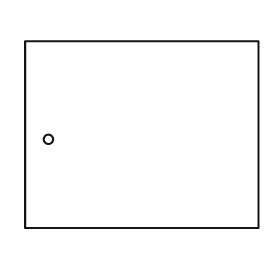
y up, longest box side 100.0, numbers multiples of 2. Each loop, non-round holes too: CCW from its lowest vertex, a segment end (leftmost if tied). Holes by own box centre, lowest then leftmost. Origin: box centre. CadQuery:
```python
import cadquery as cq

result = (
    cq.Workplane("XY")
    .moveTo(-50.0, -40.0)
    .lineTo(50.0, -40.0)
    .lineTo(50.0, 40.0)
    .lineTo(-50.0, 40.0)
    .close()
    .moveTo(-40.0, -2.0)
    .circle(2.0)
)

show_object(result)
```